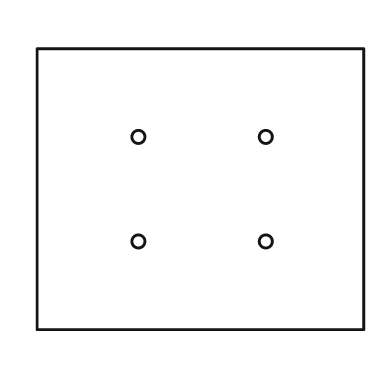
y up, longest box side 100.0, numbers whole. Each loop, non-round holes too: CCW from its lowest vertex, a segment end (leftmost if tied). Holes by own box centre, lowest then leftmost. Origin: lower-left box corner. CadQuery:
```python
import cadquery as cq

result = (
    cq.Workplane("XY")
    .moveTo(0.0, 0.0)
    .lineTo(100.0, 0.0)
    .lineTo(100.0, 86.0)
    .lineTo(0.0, 86.0)
    .close()
    .moveTo(31.0, 27.0)
    .circle(2.0)
    .moveTo(70.0, 27.0)
    .circle(2.0)
    .moveTo(31.0, 59.0)
    .circle(2.0)
    .moveTo(70.0, 59.0)
    .circle(2.0)
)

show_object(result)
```